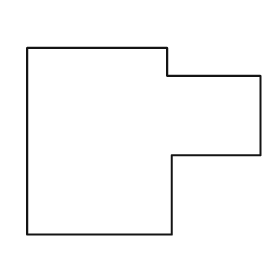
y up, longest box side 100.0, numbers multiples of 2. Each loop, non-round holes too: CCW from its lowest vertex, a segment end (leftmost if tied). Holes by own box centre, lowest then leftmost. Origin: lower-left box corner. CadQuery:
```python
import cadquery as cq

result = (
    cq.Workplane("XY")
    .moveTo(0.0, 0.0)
    .lineTo(62.0, 0.0)
    .lineTo(62.0, 34.0)
    .lineTo(100.0, 34.0)
    .lineTo(100.0, 68.0)
    .lineTo(60.0, 68.0)
    .lineTo(60.0, 80.0)
    .lineTo(0.0, 80.0)
    .close()
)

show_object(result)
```